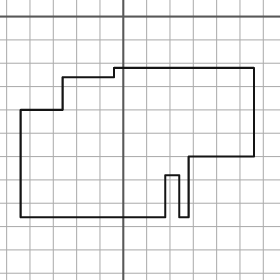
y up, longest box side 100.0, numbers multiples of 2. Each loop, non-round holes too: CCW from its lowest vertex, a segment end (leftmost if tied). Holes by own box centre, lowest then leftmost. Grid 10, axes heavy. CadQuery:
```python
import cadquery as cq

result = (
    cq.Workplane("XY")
    .moveTo(-44.0, -86.0)
    .lineTo(18.0, -86.0)
    .lineTo(18.0, -68.0)
    .lineTo(24.0, -68.0)
    .lineTo(24.0, -86.0)
    .lineTo(28.0, -86.0)
    .lineTo(28.0, -60.0)
    .lineTo(56.0, -60.0)
    .lineTo(56.0, -22.0)
    .lineTo(-4.0, -22.0)
    .lineTo(-4.0, -26.0)
    .lineTo(-26.0, -26.0)
    .lineTo(-26.0, -40.0)
    .lineTo(-44.0, -40.0)
    .close()
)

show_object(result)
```